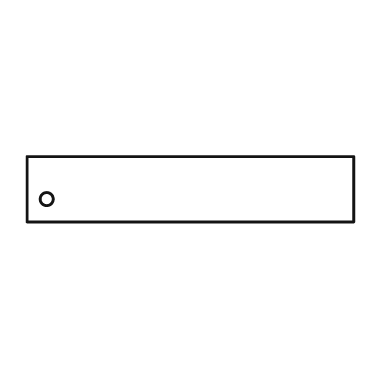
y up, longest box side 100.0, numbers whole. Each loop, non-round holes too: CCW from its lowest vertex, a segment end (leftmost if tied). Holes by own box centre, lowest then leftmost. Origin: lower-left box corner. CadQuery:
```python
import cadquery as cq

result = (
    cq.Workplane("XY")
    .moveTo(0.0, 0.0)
    .lineTo(100.0, 0.0)
    .lineTo(100.0, 20.0)
    .lineTo(0.0, 20.0)
    .close()
    .moveTo(6.0, 7.0)
    .circle(2.0)
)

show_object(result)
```